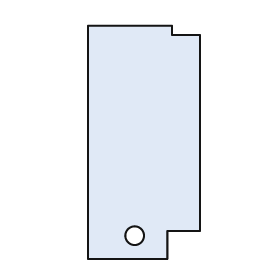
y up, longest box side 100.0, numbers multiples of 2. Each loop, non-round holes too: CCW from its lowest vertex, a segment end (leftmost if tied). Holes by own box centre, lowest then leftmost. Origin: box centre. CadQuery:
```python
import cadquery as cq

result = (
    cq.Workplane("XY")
    .moveTo(-24.0, -50.0)
    .lineTo(10.0, -50.0)
    .lineTo(10.0, -38.0)
    .lineTo(24.0, -38.0)
    .lineTo(24.0, 46.0)
    .lineTo(12.0, 46.0)
    .lineTo(12.0, 50.0)
    .lineTo(-24.0, 50.0)
    .close()
    .moveTo(-4.0, -40.0)
    .circle(4.0)
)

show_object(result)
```